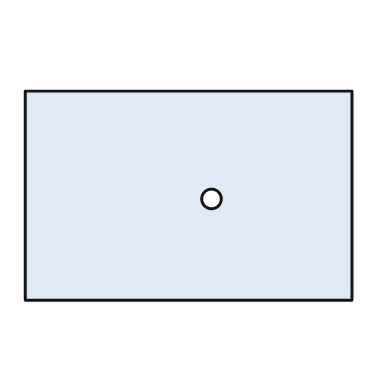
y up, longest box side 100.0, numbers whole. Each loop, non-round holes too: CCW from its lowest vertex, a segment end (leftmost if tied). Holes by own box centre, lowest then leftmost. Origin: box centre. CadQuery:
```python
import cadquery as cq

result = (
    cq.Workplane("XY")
    .moveTo(-50.0, -32.0)
    .lineTo(50.0, -32.0)
    .lineTo(50.0, 32.0)
    .lineTo(-50.0, 32.0)
    .close()
    .moveTo(7.0, -1.0)
    .circle(3.0)
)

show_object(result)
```